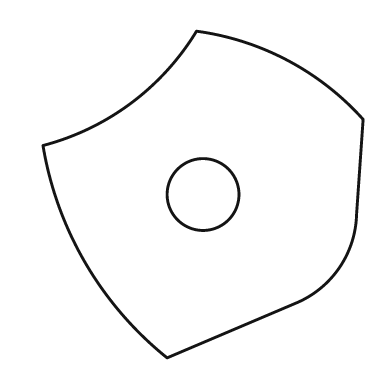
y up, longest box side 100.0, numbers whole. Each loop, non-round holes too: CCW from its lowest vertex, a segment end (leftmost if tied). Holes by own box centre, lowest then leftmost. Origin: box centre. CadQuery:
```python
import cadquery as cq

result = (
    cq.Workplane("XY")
    .moveTo(-11.0, -50.0)
    .lineTo(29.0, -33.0)
    .threePointArc((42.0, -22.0), (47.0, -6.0))
    .lineTo(49.0, 23.0)
    .threePointArc((26.0, 41.0), (-2.0, 50.0))
    .threePointArc((-22.0, 28.0), (-49.0, 15.0))
    .threePointArc((-36.0, -21.0), (-11.0, -50.0))
    .close()
    .moveTo(0.0, 0.0)
    .circle(11.0)
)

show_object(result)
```